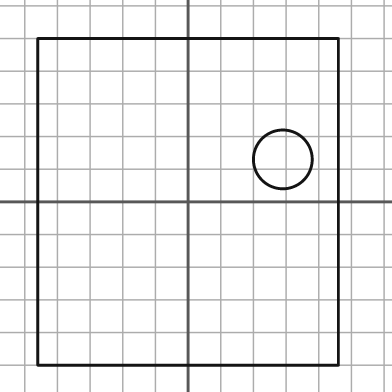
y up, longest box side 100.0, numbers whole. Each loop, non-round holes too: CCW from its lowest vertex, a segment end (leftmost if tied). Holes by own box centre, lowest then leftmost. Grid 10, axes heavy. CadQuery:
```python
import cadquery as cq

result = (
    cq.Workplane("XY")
    .moveTo(-46.0, -50.0)
    .lineTo(46.0, -50.0)
    .lineTo(46.0, 50.0)
    .lineTo(-46.0, 50.0)
    .close()
    .moveTo(29.0, 13.0)
    .circle(9.0)
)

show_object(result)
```